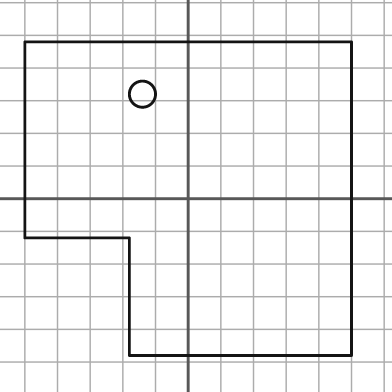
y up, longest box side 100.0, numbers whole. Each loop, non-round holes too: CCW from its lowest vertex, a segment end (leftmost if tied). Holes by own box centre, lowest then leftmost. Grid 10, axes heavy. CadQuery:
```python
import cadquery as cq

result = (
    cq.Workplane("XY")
    .moveTo(-18.0, -48.0)
    .lineTo(50.0, -48.0)
    .lineTo(50.0, 48.0)
    .lineTo(-50.0, 48.0)
    .lineTo(-50.0, -12.0)
    .lineTo(-18.0, -12.0)
    .close()
    .moveTo(-14.0, 32.0)
    .circle(4.0)
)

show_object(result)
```